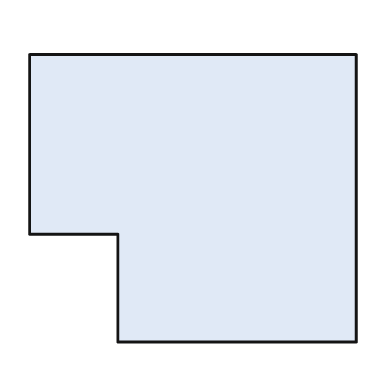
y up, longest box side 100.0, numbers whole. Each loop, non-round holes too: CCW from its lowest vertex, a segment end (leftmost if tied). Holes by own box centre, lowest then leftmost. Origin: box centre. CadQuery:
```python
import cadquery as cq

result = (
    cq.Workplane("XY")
    .moveTo(-23.0, -44.0)
    .lineTo(50.0, -44.0)
    .lineTo(50.0, 44.0)
    .lineTo(-50.0, 44.0)
    .lineTo(-50.0, -11.0)
    .lineTo(-23.0, -11.0)
    .close()
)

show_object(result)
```